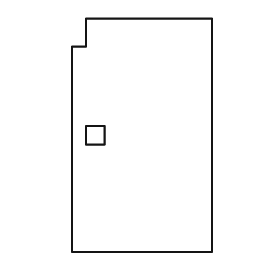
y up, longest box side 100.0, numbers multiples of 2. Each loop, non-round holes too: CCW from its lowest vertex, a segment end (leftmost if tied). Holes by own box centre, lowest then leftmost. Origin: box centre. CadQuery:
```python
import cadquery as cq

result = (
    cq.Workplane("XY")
    .moveTo(-30.0, -50.0)
    .lineTo(30.0, -50.0)
    .lineTo(30.0, 50.0)
    .lineTo(-24.0, 50.0)
    .lineTo(-24.0, 38.0)
    .lineTo(-30.0, 38.0)
    .close()
    .moveTo(-24.0, -4.0)
    .lineTo(-16.0, -4.0)
    .lineTo(-16.0, 4.0)
    .lineTo(-24.0, 4.0)
    .close()
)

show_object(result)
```